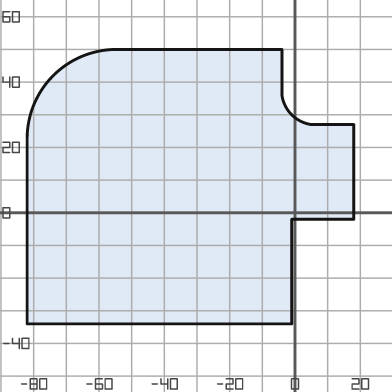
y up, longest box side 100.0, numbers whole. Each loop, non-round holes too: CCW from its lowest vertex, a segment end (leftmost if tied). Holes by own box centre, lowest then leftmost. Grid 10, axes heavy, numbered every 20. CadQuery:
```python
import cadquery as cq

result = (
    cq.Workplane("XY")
    .moveTo(-82.0, -34.0)
    .lineTo(-1.0, -34.0)
    .lineTo(-1.0, -2.0)
    .lineTo(18.0, -2.0)
    .lineTo(18.0, 27.0)
    .lineTo(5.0, 27.0)
    .threePointArc((-1.0, 30.0), (-4.0, 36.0))
    .lineTo(-4.0, 50.0)
    .lineTo(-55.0, 50.0)
    .threePointArc((-74.0, 42.0), (-82.0, 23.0))
    .close()
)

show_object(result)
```